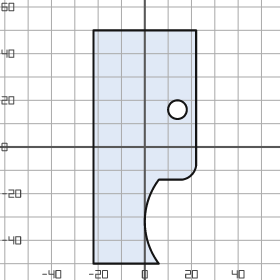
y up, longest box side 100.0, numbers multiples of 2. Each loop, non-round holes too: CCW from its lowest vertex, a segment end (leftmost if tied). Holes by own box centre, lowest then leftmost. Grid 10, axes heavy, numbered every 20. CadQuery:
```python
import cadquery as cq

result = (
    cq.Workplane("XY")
    .moveTo(-22.0, -50.0)
    .lineTo(6.0, -50.0)
    .threePointArc((0.0, -32.0), (6.0, -14.0))
    .lineTo(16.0, -14.0)
    .threePointArc((20.0, -12.0), (22.0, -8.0))
    .lineTo(22.0, 50.0)
    .lineTo(-22.0, 50.0)
    .close()
    .moveTo(14.0, 16.0)
    .circle(4.0)
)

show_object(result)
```